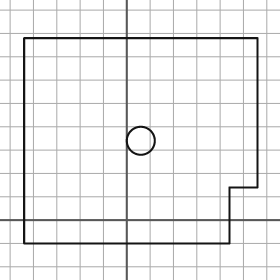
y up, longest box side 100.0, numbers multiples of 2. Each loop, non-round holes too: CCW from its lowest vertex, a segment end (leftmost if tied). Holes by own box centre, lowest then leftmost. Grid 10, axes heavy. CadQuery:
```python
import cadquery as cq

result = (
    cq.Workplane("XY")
    .moveTo(-44.0, -10.0)
    .lineTo(44.0, -10.0)
    .lineTo(44.0, 14.0)
    .lineTo(56.0, 14.0)
    .lineTo(56.0, 78.0)
    .lineTo(-44.0, 78.0)
    .close()
    .moveTo(6.0, 34.0)
    .circle(6.0)
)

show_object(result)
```